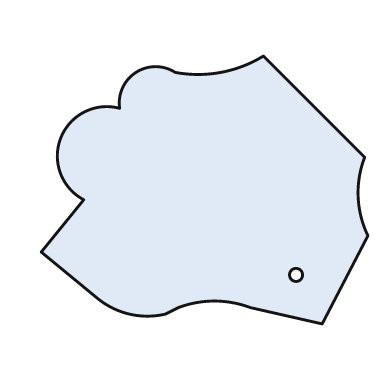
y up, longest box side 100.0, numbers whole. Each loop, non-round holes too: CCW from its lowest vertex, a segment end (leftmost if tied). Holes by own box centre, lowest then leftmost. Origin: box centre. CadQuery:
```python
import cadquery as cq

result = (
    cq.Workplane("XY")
    .moveTo(36.0, -41.0)
    .lineTo(50.0, -14.0)
    .threePointArc((47.0, -2.0), (49.0, 10.0))
    .lineTo(18.0, 41.0)
    .threePointArc((5.0, 36.0), (-9.0, 36.0))
    .threePointArc((-21.0, 36.0), (-26.0, 25.0))
    .threePointArc((-44.0, 16.0), (-37.0, -3.0))
    .lineTo(-50.0, -19.0)
    .lineTo(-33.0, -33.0)
    .threePointArc((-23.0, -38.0), (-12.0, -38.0))
    .lineTo(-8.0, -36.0)
    .threePointArc((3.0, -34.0), (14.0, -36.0))
    .close()
    .moveTo(28.0, -26.0)
    .circle(2.0)
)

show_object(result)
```